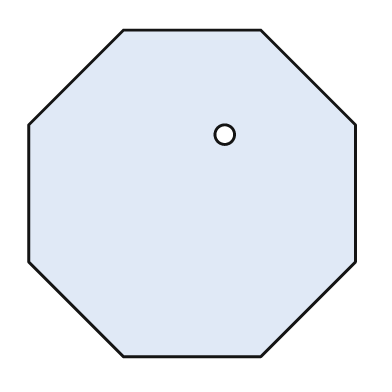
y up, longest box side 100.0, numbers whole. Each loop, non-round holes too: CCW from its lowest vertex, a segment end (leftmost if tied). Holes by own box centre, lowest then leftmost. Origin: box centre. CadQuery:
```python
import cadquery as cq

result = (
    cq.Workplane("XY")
    .moveTo(-21.0, -50.0)
    .lineTo(21.0, -50.0)
    .lineTo(50.0, -21.0)
    .lineTo(50.0, 21.0)
    .lineTo(21.0, 50.0)
    .lineTo(-21.0, 50.0)
    .lineTo(-50.0, 21.0)
    .lineTo(-50.0, -21.0)
    .close()
    .moveTo(10.0, 18.0)
    .circle(3.0)
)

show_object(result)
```